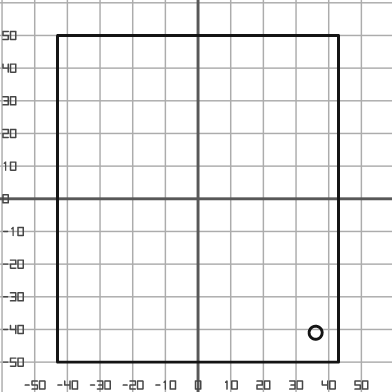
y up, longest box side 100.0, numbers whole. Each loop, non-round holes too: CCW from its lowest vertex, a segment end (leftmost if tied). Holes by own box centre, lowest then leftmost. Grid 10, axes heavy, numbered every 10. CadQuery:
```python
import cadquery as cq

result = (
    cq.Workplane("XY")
    .moveTo(-43.0, -50.0)
    .lineTo(43.0, -50.0)
    .lineTo(43.0, 50.0)
    .lineTo(-43.0, 50.0)
    .close()
    .moveTo(36.0, -41.0)
    .circle(2.0)
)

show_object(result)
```